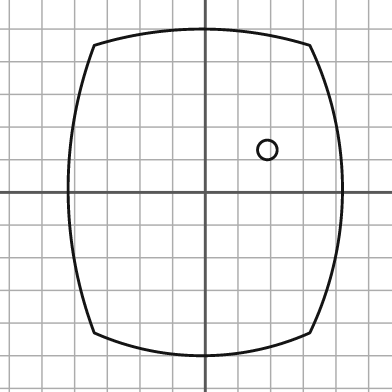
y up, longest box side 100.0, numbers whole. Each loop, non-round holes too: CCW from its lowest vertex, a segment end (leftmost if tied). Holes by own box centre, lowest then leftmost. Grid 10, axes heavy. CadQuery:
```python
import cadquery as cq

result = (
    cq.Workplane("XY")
    .moveTo(-34.0, -43.0)
    .threePointArc((-1.0, -50.0), (32.0, -43.0))
    .threePointArc((42.0, 1.0), (32.0, 45.0))
    .threePointArc((-1.0, 50.0), (-34.0, 45.0))
    .threePointArc((-42.0, 1.0), (-34.0, -43.0))
    .close()
    .moveTo(19.0, 13.0)
    .circle(3.0)
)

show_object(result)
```